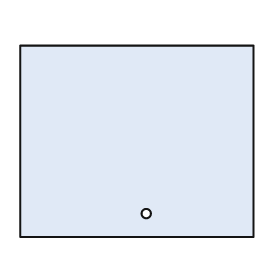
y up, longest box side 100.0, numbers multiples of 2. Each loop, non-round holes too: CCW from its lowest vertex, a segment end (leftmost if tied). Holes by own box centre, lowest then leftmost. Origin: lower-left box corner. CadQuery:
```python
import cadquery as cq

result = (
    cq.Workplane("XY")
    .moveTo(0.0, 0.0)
    .lineTo(100.0, 0.0)
    .lineTo(100.0, 82.0)
    .lineTo(0.0, 82.0)
    .close()
    .moveTo(54.0, 10.0)
    .circle(2.0)
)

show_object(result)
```